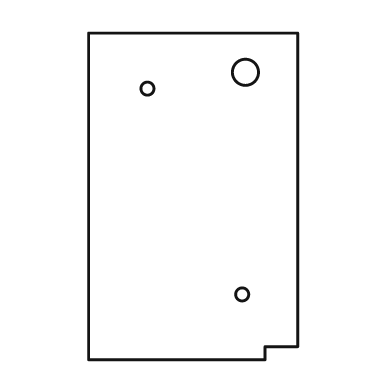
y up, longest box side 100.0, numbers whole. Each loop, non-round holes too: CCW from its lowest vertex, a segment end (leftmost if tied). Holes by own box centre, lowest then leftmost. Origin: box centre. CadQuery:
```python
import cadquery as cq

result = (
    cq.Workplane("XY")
    .moveTo(-32.0, -50.0)
    .lineTo(22.0, -50.0)
    .lineTo(22.0, -46.0)
    .lineTo(32.0, -46.0)
    .lineTo(32.0, 50.0)
    .lineTo(-32.0, 50.0)
    .close()
    .moveTo(15.0, -30.0)
    .circle(2.0)
    .moveTo(-14.0, 33.0)
    .circle(2.0)
    .moveTo(16.0, 38.0)
    .circle(4.0)
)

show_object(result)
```